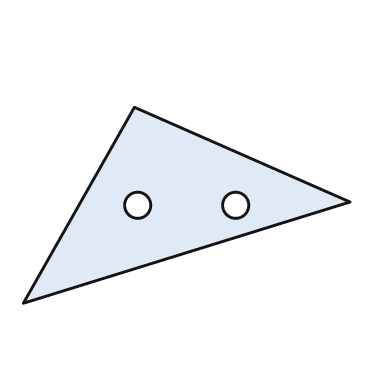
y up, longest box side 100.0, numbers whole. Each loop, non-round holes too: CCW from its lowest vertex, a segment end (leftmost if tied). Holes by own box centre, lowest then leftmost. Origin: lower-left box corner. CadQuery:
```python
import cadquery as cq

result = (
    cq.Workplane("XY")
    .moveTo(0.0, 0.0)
    .lineTo(100.0, 31.0)
    .lineTo(34.0, 60.0)
    .close()
    .moveTo(35.0, 30.0)
    .circle(4.0)
    .moveTo(65.0, 30.0)
    .circle(4.0)
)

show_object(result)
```